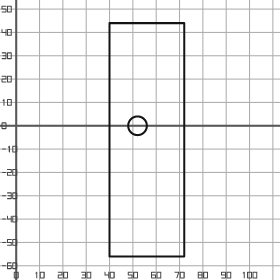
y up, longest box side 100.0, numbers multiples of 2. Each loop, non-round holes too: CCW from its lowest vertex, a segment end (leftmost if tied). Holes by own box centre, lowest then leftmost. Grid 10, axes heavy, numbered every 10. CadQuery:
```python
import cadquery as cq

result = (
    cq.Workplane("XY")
    .moveTo(40.0, -56.0)
    .lineTo(72.0, -56.0)
    .lineTo(72.0, 44.0)
    .lineTo(40.0, 44.0)
    .close()
    .moveTo(52.0, 0.0)
    .circle(4.0)
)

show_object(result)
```